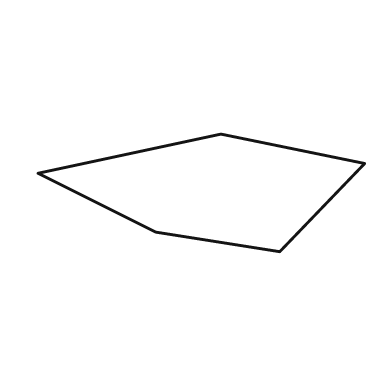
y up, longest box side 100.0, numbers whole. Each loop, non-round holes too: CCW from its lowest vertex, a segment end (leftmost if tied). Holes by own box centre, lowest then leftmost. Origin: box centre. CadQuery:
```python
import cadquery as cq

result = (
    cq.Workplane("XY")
    .moveTo(24.0, -18.0)
    .lineTo(50.0, 9.0)
    .lineTo(6.0, 18.0)
    .lineTo(-50.0, 6.0)
    .lineTo(-14.0, -12.0)
    .close()
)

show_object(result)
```